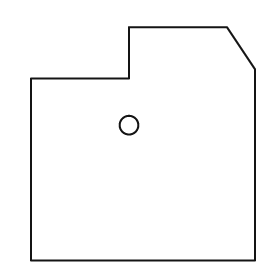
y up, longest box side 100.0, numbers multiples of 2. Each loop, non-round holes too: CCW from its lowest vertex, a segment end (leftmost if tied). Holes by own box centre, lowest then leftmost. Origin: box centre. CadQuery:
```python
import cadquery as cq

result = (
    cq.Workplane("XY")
    .moveTo(-48.0, -50.0)
    .lineTo(48.0, -50.0)
    .lineTo(48.0, 32.0)
    .lineTo(36.0, 50.0)
    .lineTo(-6.0, 50.0)
    .lineTo(-6.0, 28.0)
    .lineTo(-48.0, 28.0)
    .close()
    .moveTo(-6.0, 8.0)
    .circle(4.0)
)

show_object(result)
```